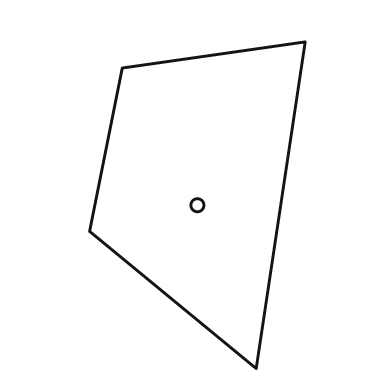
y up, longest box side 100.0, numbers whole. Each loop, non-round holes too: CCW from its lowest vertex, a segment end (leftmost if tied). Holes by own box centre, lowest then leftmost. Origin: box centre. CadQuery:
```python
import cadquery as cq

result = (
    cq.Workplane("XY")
    .moveTo(18.0, -50.0)
    .lineTo(33.0, 50.0)
    .lineTo(-23.0, 42.0)
    .lineTo(-33.0, -8.0)
    .close()
    .moveTo(0.0, 0.0)
    .circle(2.0)
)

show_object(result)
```